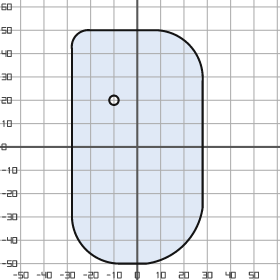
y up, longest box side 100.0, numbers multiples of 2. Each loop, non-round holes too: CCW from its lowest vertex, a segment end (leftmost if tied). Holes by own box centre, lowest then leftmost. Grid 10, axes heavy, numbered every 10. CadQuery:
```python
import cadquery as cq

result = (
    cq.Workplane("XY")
    .moveTo(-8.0, -50.0)
    .lineTo(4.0, -50.0)
    .threePointArc((20.0, -42.0), (28.0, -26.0))
    .lineTo(28.0, 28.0)
    .threePointArc((22.0, 44.0), (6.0, 50.0))
    .lineTo(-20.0, 50.0)
    .threePointArc((-26.0, 48.0), (-28.0, 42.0))
    .lineTo(-28.0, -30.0)
    .threePointArc((-22.0, -44.0), (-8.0, -50.0))
    .close()
    .moveTo(-10.0, 20.0)
    .circle(2.0)
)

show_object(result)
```